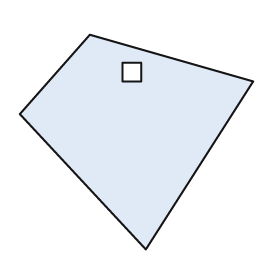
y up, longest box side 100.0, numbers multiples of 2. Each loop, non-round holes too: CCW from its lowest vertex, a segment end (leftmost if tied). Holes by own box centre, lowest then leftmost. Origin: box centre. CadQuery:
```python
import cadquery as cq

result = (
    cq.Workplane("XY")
    .moveTo(4.0, -46.0)
    .lineTo(50.0, 26.0)
    .lineTo(-20.0, 46.0)
    .lineTo(-50.0, 12.0)
    .close()
    .moveTo(-6.0, 26.0)
    .lineTo(2.0, 26.0)
    .lineTo(2.0, 34.0)
    .lineTo(-6.0, 34.0)
    .close()
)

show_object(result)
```